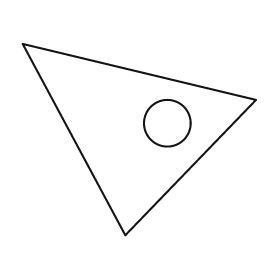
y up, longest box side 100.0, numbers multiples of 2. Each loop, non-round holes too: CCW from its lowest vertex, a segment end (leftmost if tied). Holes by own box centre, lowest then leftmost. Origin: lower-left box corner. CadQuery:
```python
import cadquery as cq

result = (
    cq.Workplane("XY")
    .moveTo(44.0, 0.0)
    .lineTo(100.0, 58.0)
    .lineTo(0.0, 82.0)
    .close()
    .moveTo(62.0, 48.0)
    .circle(10.0)
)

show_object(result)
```